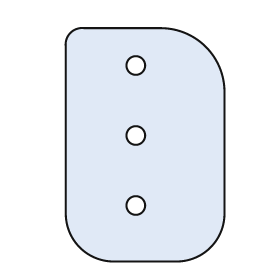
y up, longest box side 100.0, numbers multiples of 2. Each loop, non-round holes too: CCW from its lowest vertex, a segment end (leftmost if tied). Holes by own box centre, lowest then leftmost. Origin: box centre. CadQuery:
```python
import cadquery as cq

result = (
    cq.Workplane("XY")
    .moveTo(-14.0, -50.0)
    .lineTo(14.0, -50.0)
    .threePointArc((28.0, -44.0), (34.0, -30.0))
    .lineTo(34.0, 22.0)
    .threePointArc((26.0, 42.0), (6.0, 50.0))
    .lineTo(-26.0, 50.0)
    .threePointArc((-32.0, 48.0), (-34.0, 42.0))
    .lineTo(-34.0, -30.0)
    .threePointArc((-28.0, -44.0), (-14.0, -50.0))
    .close()
    .moveTo(-4.0, -26.0)
    .circle(4.0)
    .moveTo(-4.0, 4.0)
    .circle(4.0)
    .moveTo(-4.0, 34.0)
    .circle(4.0)
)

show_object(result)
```